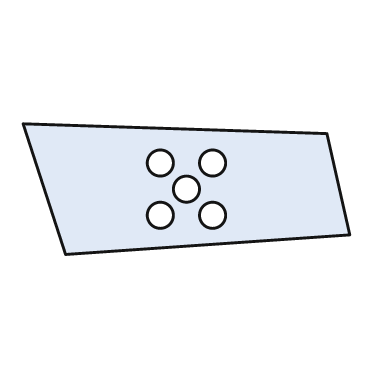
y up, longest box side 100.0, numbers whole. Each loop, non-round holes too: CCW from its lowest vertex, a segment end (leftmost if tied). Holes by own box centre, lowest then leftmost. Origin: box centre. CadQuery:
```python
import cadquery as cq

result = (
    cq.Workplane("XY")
    .moveTo(-37.0, -20.0)
    .lineTo(50.0, -14.0)
    .lineTo(43.0, 17.0)
    .lineTo(-50.0, 20.0)
    .close()
    .moveTo(-8.0, -8.0)
    .circle(4.0)
    .moveTo(8.0, -8.0)
    .circle(4.0)
    .moveTo(0.0, 0.0)
    .circle(4.0)
    .moveTo(-8.0, 8.0)
    .circle(4.0)
    .moveTo(8.0, 8.0)
    .circle(4.0)
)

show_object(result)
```